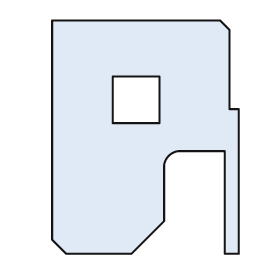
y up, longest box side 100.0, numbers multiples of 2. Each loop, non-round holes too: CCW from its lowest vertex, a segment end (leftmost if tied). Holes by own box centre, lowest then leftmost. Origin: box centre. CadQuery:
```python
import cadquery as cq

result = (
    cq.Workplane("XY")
    .moveTo(-34.0, -50.0)
    .lineTo(-6.0, -50.0)
    .lineTo(8.0, -36.0)
    .lineTo(8.0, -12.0)
    .threePointArc((10.0, -8.0), (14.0, -6.0))
    .lineTo(34.0, -6.0)
    .lineTo(34.0, -50.0)
    .lineTo(40.0, -50.0)
    .lineTo(40.0, 12.0)
    .lineTo(36.0, 12.0)
    .lineTo(36.0, 46.0)
    .lineTo(32.0, 50.0)
    .lineTo(-40.0, 50.0)
    .lineTo(-40.0, -44.0)
    .close()
    .moveTo(-14.0, 6.0)
    .lineTo(6.0, 6.0)
    .lineTo(6.0, 26.0)
    .lineTo(-14.0, 26.0)
    .close()
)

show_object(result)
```